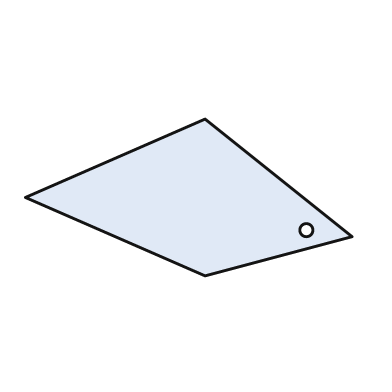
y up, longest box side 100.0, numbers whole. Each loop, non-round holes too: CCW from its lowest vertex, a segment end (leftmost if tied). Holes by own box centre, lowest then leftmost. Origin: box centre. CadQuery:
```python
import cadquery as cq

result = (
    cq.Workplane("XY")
    .moveTo(5.0, -24.0)
    .lineTo(50.0, -12.0)
    .lineTo(5.0, 24.0)
    .lineTo(-50.0, 0.0)
    .close()
    .moveTo(36.0, -10.0)
    .circle(2.0)
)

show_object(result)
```